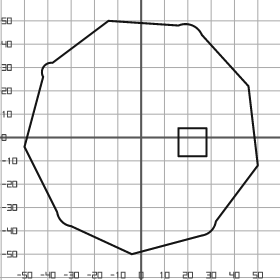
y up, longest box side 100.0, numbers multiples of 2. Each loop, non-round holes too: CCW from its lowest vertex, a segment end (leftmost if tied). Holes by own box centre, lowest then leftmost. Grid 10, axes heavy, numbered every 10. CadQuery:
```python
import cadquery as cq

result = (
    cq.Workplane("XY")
    .moveTo(-4.0, -50.0)
    .lineTo(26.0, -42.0)
    .threePointArc((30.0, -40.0), (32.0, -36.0))
    .lineTo(50.0, -12.0)
    .lineTo(46.0, 22.0)
    .lineTo(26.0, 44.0)
    .threePointArc((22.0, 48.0), (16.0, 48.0))
    .lineTo(-14.0, 50.0)
    .lineTo(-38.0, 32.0)
    .threePointArc((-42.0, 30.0), (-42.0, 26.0))
    .lineTo(-50.0, -4.0)
    .lineTo(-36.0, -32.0)
    .threePointArc((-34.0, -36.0), (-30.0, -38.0))
    .close()
    .moveTo(16.0, -8.0)
    .lineTo(28.0, -8.0)
    .lineTo(28.0, 4.0)
    .lineTo(16.0, 4.0)
    .close()
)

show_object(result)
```